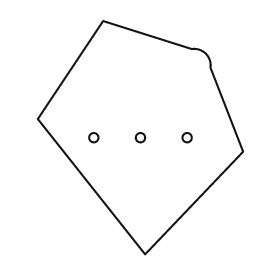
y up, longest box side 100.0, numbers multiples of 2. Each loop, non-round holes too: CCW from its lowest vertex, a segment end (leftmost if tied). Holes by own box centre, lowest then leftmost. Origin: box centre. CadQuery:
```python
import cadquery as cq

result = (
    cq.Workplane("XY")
    .moveTo(2.0, -50.0)
    .lineTo(44.0, -6.0)
    .lineTo(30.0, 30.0)
    .threePointArc((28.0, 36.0), (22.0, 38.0))
    .lineTo(-16.0, 50.0)
    .lineTo(-44.0, 8.0)
    .close()
    .moveTo(-20.0, 0.0)
    .circle(2.0)
    .moveTo(0.0, 0.0)
    .circle(2.0)
    .moveTo(20.0, 0.0)
    .circle(2.0)
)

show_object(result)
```